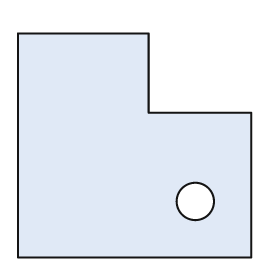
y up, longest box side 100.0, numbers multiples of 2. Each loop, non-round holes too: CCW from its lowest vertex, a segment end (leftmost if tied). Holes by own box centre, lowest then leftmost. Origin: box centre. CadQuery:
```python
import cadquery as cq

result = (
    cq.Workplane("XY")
    .moveTo(-50.0, -48.0)
    .lineTo(50.0, -48.0)
    .lineTo(50.0, 14.0)
    .lineTo(6.0, 14.0)
    .lineTo(6.0, 48.0)
    .lineTo(-50.0, 48.0)
    .close()
    .moveTo(26.0, -24.0)
    .circle(8.0)
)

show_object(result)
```